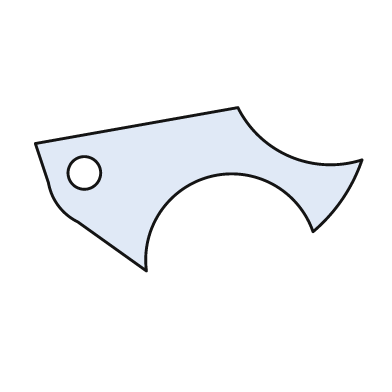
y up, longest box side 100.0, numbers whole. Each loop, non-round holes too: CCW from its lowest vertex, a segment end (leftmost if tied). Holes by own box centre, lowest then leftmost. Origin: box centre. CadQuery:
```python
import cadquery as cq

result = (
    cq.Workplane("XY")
    .moveTo(-16.0, -25.0)
    .threePointArc((4.0, 4.0), (35.0, -13.0))
    .threePointArc((44.0, -3.0), (50.0, 9.0))
    .threePointArc((28.0, 10.0), (12.0, 25.0))
    .lineTo(-50.0, 14.0)
    .lineTo(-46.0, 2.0)
    .threePointArc((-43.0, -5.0), (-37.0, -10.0))
    .close()
    .moveTo(-35.0, 5.0)
    .circle(5.0)
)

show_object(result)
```